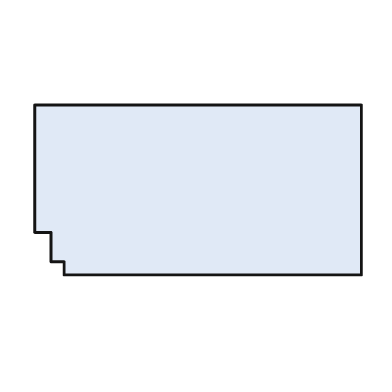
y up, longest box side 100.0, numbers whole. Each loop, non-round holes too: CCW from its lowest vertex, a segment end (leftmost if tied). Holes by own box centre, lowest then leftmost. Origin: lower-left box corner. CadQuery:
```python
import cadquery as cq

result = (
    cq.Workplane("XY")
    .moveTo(9.0, 0.0)
    .lineTo(100.0, 0.0)
    .lineTo(100.0, 52.0)
    .lineTo(0.0, 52.0)
    .lineTo(0.0, 13.0)
    .lineTo(5.0, 13.0)
    .lineTo(5.0, 4.0)
    .lineTo(9.0, 4.0)
    .close()
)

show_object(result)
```